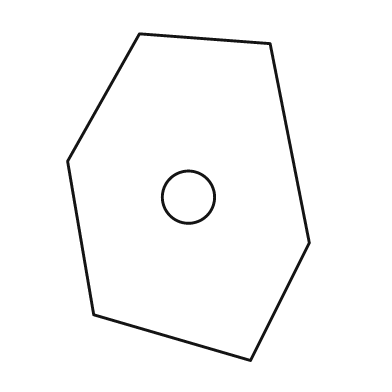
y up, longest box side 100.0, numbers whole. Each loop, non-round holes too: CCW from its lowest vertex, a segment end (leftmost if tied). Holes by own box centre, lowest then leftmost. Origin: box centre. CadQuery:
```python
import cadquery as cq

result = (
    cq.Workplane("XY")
    .moveTo(19.0, -50.0)
    .lineTo(37.0, -14.0)
    .lineTo(25.0, 47.0)
    .lineTo(-15.0, 50.0)
    .lineTo(-37.0, 11.0)
    .lineTo(-29.0, -36.0)
    .close()
    .moveTo(0.0, 0.0)
    .circle(8.0)
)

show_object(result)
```